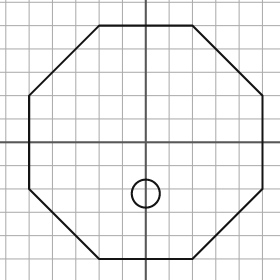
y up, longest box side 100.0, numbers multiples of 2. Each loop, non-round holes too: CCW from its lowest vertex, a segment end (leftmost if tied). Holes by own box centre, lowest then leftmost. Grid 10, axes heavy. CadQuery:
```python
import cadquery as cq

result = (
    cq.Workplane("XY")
    .moveTo(-20.0, -50.0)
    .lineTo(20.0, -50.0)
    .lineTo(50.0, -20.0)
    .lineTo(50.0, 20.0)
    .lineTo(20.0, 50.0)
    .lineTo(-20.0, 50.0)
    .lineTo(-50.0, 20.0)
    .lineTo(-50.0, -20.0)
    .close()
    .moveTo(0.0, -22.0)
    .circle(6.0)
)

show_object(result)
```